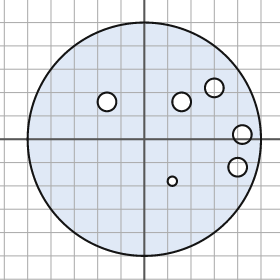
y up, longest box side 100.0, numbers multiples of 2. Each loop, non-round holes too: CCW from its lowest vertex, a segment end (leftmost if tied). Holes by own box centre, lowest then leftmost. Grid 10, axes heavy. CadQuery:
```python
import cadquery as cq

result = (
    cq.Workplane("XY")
    .moveTo(0.0, 0.0)
    .circle(50.0)
    .moveTo(12.0, -18.0)
    .circle(2.0)
    .moveTo(40.0, -12.0)
    .circle(4.0)
    .moveTo(42.0, 2.0)
    .circle(4.0)
    .moveTo(-16.0, 16.0)
    .circle(4.0)
    .moveTo(16.0, 16.0)
    .circle(4.0)
    .moveTo(30.0, 22.0)
    .circle(4.0)
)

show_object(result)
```